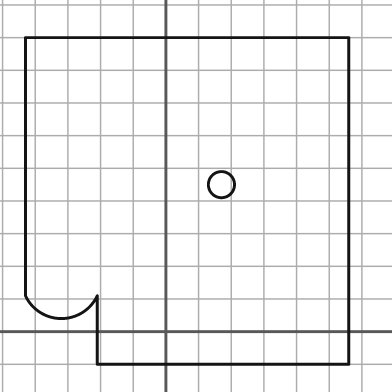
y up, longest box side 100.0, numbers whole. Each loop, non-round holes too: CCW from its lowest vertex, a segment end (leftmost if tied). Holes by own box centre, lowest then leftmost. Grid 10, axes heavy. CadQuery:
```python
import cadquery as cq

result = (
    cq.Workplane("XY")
    .moveTo(-21.0, -10.0)
    .lineTo(56.0, -10.0)
    .lineTo(56.0, 90.0)
    .lineTo(-43.0, 90.0)
    .lineTo(-43.0, 11.0)
    .threePointArc((-32.0, 4.0), (-21.0, 11.0))
    .close()
    .moveTo(17.0, 45.0)
    .circle(4.0)
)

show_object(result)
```